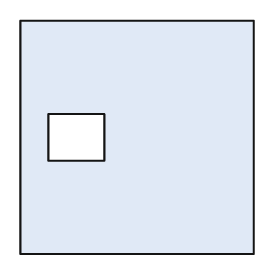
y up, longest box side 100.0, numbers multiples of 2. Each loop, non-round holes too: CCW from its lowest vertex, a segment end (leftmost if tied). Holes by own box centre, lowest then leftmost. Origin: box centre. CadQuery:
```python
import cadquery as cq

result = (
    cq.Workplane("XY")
    .moveTo(-50.0, -50.0)
    .lineTo(50.0, -50.0)
    .lineTo(50.0, 50.0)
    .lineTo(-50.0, 50.0)
    .close()
    .moveTo(-38.0, -10.0)
    .lineTo(-14.0, -10.0)
    .lineTo(-14.0, 10.0)
    .lineTo(-38.0, 10.0)
    .close()
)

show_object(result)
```